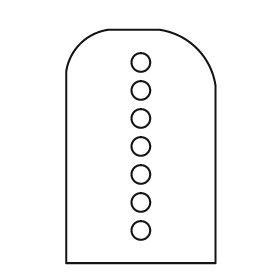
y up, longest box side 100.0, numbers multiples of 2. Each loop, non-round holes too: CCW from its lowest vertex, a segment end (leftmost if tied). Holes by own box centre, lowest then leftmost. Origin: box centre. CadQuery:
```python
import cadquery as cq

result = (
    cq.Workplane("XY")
    .moveTo(-32.0, -50.0)
    .lineTo(32.0, -50.0)
    .lineTo(32.0, 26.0)
    .threePointArc((24.0, 42.0), (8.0, 50.0))
    .lineTo(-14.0, 50.0)
    .threePointArc((-26.0, 44.0), (-32.0, 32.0))
    .close()
    .moveTo(0.0, -36.0)
    .circle(4.0)
    .moveTo(0.0, -24.0)
    .circle(4.0)
    .moveTo(0.0, -12.0)
    .circle(4.0)
    .moveTo(0.0, 0.0)
    .circle(4.0)
    .moveTo(0.0, 12.0)
    .circle(4.0)
    .moveTo(0.0, 24.0)
    .circle(4.0)
    .moveTo(0.0, 36.0)
    .circle(4.0)
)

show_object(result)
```